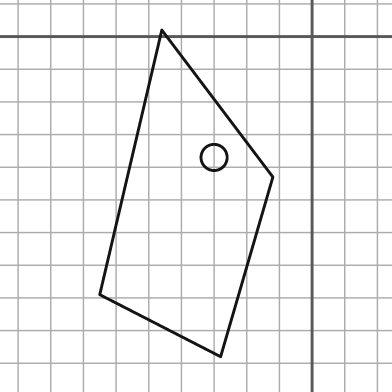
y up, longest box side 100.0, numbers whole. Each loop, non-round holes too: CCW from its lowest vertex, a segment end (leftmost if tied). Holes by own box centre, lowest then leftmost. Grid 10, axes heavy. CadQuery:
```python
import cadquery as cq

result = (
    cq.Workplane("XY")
    .moveTo(-28.0, -98.0)
    .lineTo(-12.0, -43.0)
    .lineTo(-46.0, 2.0)
    .lineTo(-65.0, -79.0)
    .close()
    .moveTo(-30.0, -37.0)
    .circle(4.0)
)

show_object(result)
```